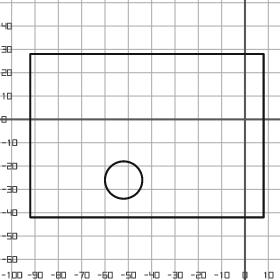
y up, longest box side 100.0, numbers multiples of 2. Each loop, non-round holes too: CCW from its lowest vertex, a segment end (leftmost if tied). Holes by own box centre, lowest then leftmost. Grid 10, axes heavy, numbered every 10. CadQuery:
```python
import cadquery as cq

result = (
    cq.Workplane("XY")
    .moveTo(-92.0, -42.0)
    .lineTo(8.0, -42.0)
    .lineTo(8.0, 28.0)
    .lineTo(-92.0, 28.0)
    .close()
    .moveTo(-52.0, -26.0)
    .circle(8.0)
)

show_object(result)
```